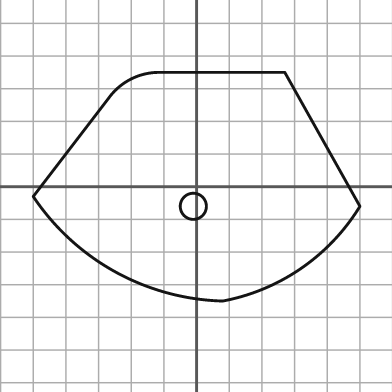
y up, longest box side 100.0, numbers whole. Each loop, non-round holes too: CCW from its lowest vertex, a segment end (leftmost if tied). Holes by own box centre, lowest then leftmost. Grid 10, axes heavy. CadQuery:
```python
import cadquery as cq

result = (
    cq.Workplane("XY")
    .moveTo(8.0, -35.0)
    .threePointArc((32.0, -25.0), (50.0, -6.0))
    .lineTo(27.0, 35.0)
    .lineTo(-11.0, 35.0)
    .threePointArc((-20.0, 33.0), (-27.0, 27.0))
    .lineTo(-50.0, -3.0)
    .threePointArc((-25.0, -26.0), (8.0, -35.0))
    .close()
    .moveTo(-1.0, -6.0)
    .circle(4.0)
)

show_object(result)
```